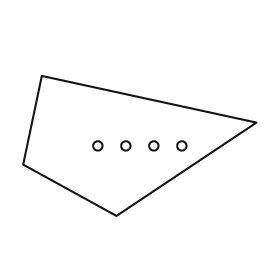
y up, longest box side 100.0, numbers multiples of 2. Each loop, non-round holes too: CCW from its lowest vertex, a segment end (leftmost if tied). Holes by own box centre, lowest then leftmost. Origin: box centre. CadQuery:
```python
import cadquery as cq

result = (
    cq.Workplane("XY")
    .moveTo(-10.0, -30.0)
    .lineTo(50.0, 10.0)
    .lineTo(-42.0, 30.0)
    .lineTo(-50.0, -8.0)
    .close()
    .moveTo(-18.0, 0.0)
    .circle(2.0)
    .moveTo(-6.0, 0.0)
    .circle(2.0)
    .moveTo(6.0, 0.0)
    .circle(2.0)
    .moveTo(18.0, 0.0)
    .circle(2.0)
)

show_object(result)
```